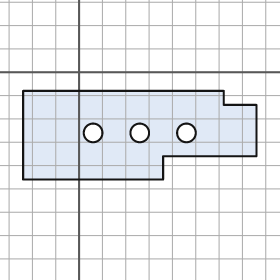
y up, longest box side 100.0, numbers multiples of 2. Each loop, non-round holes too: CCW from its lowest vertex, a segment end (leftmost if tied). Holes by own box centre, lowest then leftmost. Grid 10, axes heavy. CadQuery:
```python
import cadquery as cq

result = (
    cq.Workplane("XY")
    .moveTo(-24.0, -46.0)
    .lineTo(36.0, -46.0)
    .lineTo(36.0, -36.0)
    .lineTo(76.0, -36.0)
    .lineTo(76.0, -14.0)
    .lineTo(62.0, -14.0)
    .lineTo(62.0, -8.0)
    .lineTo(-24.0, -8.0)
    .close()
    .moveTo(6.0, -26.0)
    .circle(4.0)
    .moveTo(26.0, -26.0)
    .circle(4.0)
    .moveTo(46.0, -26.0)
    .circle(4.0)
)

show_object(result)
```